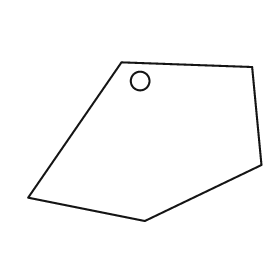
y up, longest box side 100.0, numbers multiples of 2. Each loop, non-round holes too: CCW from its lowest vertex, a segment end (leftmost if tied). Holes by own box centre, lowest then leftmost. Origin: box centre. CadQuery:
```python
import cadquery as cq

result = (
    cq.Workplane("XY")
    .moveTo(0.0, -34.0)
    .lineTo(50.0, -10.0)
    .lineTo(46.0, 32.0)
    .lineTo(-10.0, 34.0)
    .lineTo(-50.0, -24.0)
    .close()
    .moveTo(-2.0, 26.0)
    .circle(4.0)
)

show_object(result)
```